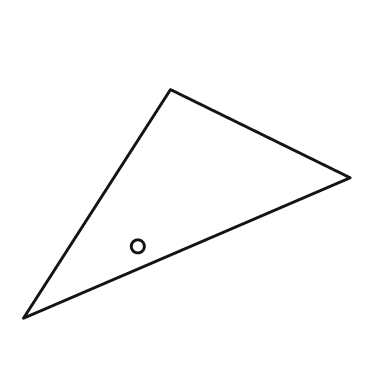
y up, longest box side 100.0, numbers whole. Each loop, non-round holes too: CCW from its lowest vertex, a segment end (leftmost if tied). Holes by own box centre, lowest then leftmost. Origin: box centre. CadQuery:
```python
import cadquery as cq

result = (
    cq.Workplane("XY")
    .moveTo(-50.0, -35.0)
    .lineTo(50.0, 8.0)
    .lineTo(-5.0, 35.0)
    .close()
    .moveTo(-15.0, -13.0)
    .circle(2.0)
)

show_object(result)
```